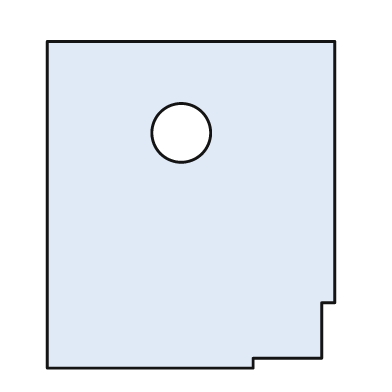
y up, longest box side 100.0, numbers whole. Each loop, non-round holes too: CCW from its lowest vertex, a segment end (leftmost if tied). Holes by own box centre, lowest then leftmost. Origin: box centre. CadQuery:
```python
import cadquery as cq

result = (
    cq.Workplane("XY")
    .moveTo(-44.0, -50.0)
    .lineTo(19.0, -50.0)
    .lineTo(19.0, -47.0)
    .lineTo(40.0, -47.0)
    .lineTo(40.0, -30.0)
    .lineTo(44.0, -30.0)
    .lineTo(44.0, 50.0)
    .lineTo(-44.0, 50.0)
    .close()
    .moveTo(-3.0, 22.0)
    .circle(9.0)
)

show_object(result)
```